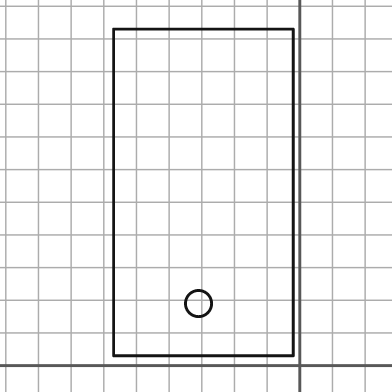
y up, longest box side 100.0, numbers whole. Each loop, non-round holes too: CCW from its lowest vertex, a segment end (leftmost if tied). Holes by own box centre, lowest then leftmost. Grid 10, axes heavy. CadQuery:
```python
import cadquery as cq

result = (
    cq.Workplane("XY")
    .moveTo(-57.0, 3.0)
    .lineTo(-2.0, 3.0)
    .lineTo(-2.0, 103.0)
    .lineTo(-57.0, 103.0)
    .close()
    .moveTo(-31.0, 19.0)
    .circle(4.0)
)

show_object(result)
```